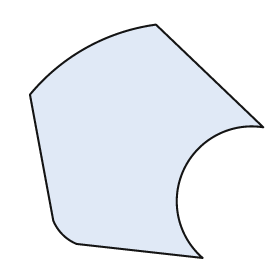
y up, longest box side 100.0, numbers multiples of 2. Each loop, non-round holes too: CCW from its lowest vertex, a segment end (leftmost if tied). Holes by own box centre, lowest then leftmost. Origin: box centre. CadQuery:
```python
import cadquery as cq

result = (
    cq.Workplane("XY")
    .moveTo(24.0, -50.0)
    .threePointArc((16.0, -12.0), (50.0, 6.0))
    .lineTo(4.0, 50.0)
    .threePointArc((-26.0, 40.0), (-50.0, 20.0))
    .lineTo(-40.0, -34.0)
    .threePointArc((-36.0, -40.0), (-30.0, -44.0))
    .close()
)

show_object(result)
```